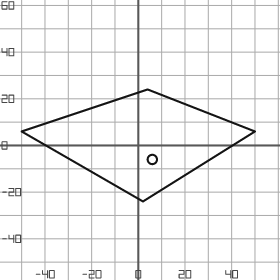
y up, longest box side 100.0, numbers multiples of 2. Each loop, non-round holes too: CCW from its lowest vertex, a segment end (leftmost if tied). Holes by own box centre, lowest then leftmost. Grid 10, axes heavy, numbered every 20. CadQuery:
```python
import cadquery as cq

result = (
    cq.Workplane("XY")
    .moveTo(2.0, -24.0)
    .lineTo(50.0, 6.0)
    .lineTo(4.0, 24.0)
    .lineTo(-50.0, 6.0)
    .close()
    .moveTo(6.0, -6.0)
    .circle(2.0)
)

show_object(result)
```